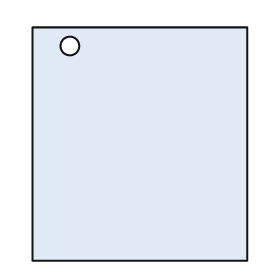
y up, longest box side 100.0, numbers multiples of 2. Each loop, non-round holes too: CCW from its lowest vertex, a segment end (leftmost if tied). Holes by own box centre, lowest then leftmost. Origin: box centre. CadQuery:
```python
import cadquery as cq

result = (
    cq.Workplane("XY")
    .moveTo(-46.0, -50.0)
    .lineTo(46.0, -50.0)
    .lineTo(46.0, 50.0)
    .lineTo(-46.0, 50.0)
    .close()
    .moveTo(-30.0, 42.0)
    .circle(4.0)
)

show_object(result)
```